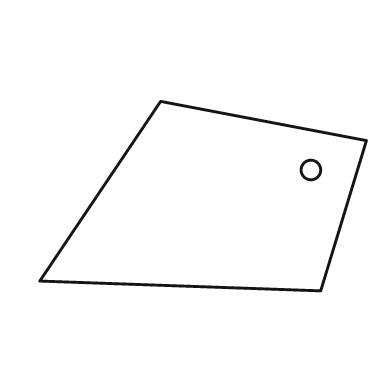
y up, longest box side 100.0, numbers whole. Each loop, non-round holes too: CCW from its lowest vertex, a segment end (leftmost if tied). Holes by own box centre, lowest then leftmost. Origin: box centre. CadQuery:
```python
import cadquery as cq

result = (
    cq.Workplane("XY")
    .moveTo(36.0, -29.0)
    .lineTo(50.0, 17.0)
    .lineTo(-13.0, 29.0)
    .lineTo(-50.0, -26.0)
    .close()
    .moveTo(33.0, 8.0)
    .circle(3.0)
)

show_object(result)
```